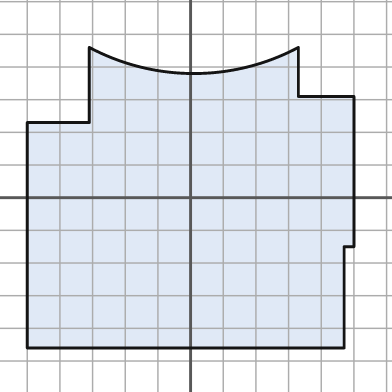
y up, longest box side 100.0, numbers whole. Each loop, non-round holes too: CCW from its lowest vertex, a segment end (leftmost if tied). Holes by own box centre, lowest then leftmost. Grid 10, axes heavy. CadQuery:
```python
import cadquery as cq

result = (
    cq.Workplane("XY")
    .moveTo(-50.0, -46.0)
    .lineTo(47.0, -46.0)
    .lineTo(47.0, -15.0)
    .lineTo(50.0, -15.0)
    .lineTo(50.0, 31.0)
    .lineTo(33.0, 31.0)
    .lineTo(33.0, 46.0)
    .threePointArc((1.0, 38.0), (-31.0, 46.0))
    .lineTo(-31.0, 23.0)
    .lineTo(-50.0, 23.0)
    .close()
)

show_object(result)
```